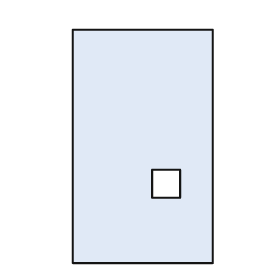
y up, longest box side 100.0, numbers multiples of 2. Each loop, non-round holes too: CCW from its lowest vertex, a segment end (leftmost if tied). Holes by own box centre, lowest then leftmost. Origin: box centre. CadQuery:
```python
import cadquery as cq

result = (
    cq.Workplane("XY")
    .moveTo(-30.0, -50.0)
    .lineTo(30.0, -50.0)
    .lineTo(30.0, 50.0)
    .lineTo(-30.0, 50.0)
    .close()
    .moveTo(4.0, -22.0)
    .lineTo(16.0, -22.0)
    .lineTo(16.0, -10.0)
    .lineTo(4.0, -10.0)
    .close()
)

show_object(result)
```